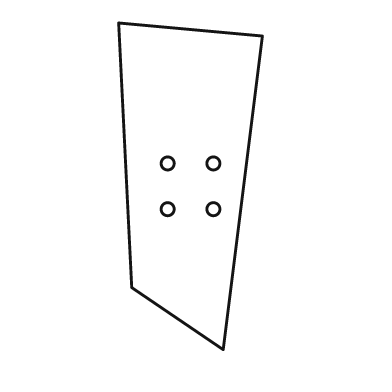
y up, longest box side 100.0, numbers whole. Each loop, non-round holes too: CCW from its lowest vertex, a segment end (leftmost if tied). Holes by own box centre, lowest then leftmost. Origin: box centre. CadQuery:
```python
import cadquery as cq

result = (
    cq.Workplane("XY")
    .moveTo(10.0, -50.0)
    .lineTo(22.0, 46.0)
    .lineTo(-22.0, 50.0)
    .lineTo(-18.0, -31.0)
    .close()
    .moveTo(-7.0, -7.0)
    .circle(2.0)
    .moveTo(7.0, -7.0)
    .circle(2.0)
    .moveTo(-7.0, 7.0)
    .circle(2.0)
    .moveTo(7.0, 7.0)
    .circle(2.0)
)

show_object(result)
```